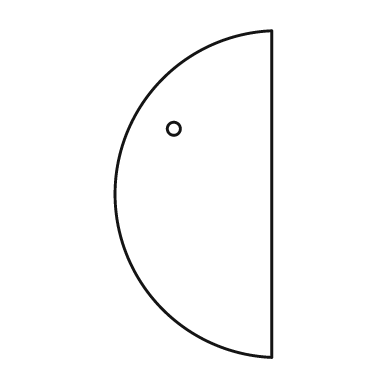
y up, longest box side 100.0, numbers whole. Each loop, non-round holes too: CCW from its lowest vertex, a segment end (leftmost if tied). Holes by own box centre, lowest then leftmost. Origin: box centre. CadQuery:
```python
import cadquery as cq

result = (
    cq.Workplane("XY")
    .moveTo(24.0, -50.0)
    .lineTo(24.0, 50.0)
    .threePointArc((-24.0, 0.0), (24.0, -50.0))
    .close()
    .moveTo(-6.0, 20.0)
    .circle(2.0)
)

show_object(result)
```